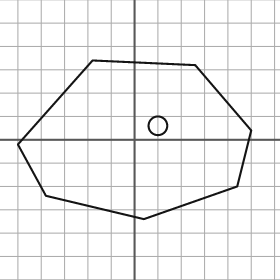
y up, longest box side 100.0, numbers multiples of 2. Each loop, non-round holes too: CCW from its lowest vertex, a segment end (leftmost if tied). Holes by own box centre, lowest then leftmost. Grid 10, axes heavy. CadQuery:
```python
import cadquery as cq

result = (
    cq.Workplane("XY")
    .moveTo(4.0, -34.0)
    .lineTo(44.0, -20.0)
    .lineTo(50.0, 4.0)
    .lineTo(26.0, 32.0)
    .lineTo(-18.0, 34.0)
    .lineTo(-50.0, -2.0)
    .lineTo(-38.0, -24.0)
    .close()
    .moveTo(10.0, 6.0)
    .circle(4.0)
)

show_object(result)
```